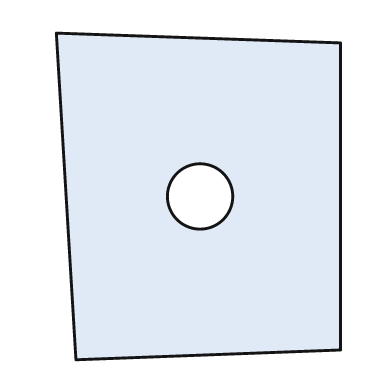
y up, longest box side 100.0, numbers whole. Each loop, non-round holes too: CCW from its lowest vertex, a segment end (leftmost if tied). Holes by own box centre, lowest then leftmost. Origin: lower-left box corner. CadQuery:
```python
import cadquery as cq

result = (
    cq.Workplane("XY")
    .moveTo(6.0, 0.0)
    .lineTo(87.0, 3.0)
    .lineTo(87.0, 97.0)
    .lineTo(0.0, 100.0)
    .close()
    .moveTo(44.0, 50.0)
    .circle(10.0)
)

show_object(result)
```